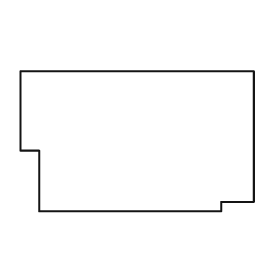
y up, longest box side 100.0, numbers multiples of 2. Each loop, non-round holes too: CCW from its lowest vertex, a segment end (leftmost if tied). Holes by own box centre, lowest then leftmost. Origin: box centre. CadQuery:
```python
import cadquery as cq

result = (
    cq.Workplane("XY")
    .moveTo(-42.0, -30.0)
    .lineTo(36.0, -30.0)
    .lineTo(36.0, -26.0)
    .lineTo(50.0, -26.0)
    .lineTo(50.0, 30.0)
    .lineTo(-50.0, 30.0)
    .lineTo(-50.0, -4.0)
    .lineTo(-42.0, -4.0)
    .close()
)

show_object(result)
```